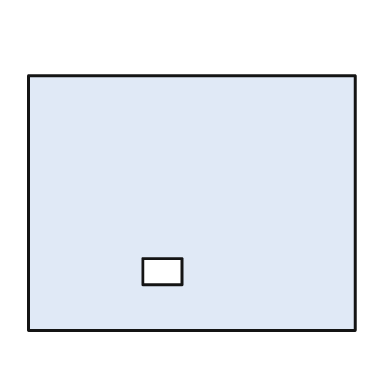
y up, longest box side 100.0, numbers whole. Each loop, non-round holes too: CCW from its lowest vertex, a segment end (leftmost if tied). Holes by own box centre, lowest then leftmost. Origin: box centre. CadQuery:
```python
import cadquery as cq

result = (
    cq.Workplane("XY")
    .moveTo(-50.0, -39.0)
    .lineTo(50.0, -39.0)
    .lineTo(50.0, 39.0)
    .lineTo(-50.0, 39.0)
    .close()
    .moveTo(-15.0, -25.0)
    .lineTo(-3.0, -25.0)
    .lineTo(-3.0, -17.0)
    .lineTo(-15.0, -17.0)
    .close()
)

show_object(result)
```